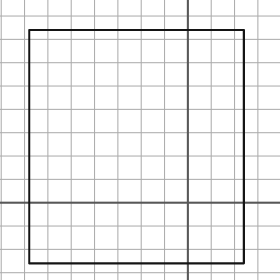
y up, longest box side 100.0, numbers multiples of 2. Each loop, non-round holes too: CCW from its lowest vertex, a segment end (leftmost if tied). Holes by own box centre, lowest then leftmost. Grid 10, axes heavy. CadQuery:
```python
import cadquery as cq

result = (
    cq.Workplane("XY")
    .moveTo(-68.0, -26.0)
    .lineTo(24.0, -26.0)
    .lineTo(24.0, 74.0)
    .lineTo(-68.0, 74.0)
    .close()
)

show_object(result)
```